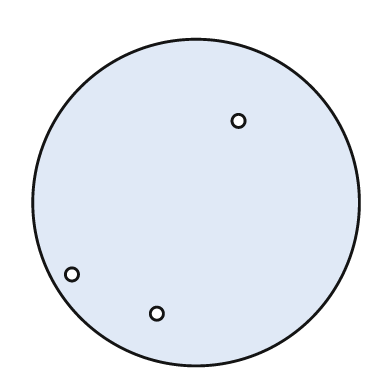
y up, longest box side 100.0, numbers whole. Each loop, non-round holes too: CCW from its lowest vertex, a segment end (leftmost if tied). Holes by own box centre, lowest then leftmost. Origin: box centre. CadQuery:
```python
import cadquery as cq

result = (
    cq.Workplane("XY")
    .moveTo(0.0, 0.0)
    .circle(50.0)
    .moveTo(-12.0, -34.0)
    .circle(2.0)
    .moveTo(-38.0, -22.0)
    .circle(2.0)
    .moveTo(13.0, 25.0)
    .circle(2.0)
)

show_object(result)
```